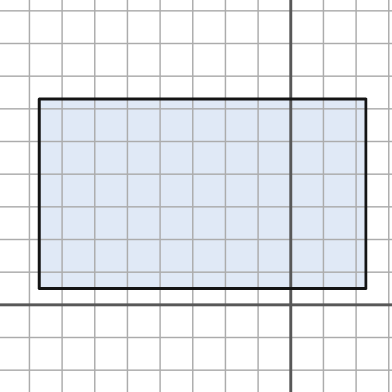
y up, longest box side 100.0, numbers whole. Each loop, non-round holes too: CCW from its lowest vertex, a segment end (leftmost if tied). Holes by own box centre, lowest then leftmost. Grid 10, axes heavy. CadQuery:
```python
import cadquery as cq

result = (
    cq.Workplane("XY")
    .moveTo(-77.0, 5.0)
    .lineTo(23.0, 5.0)
    .lineTo(23.0, 63.0)
    .lineTo(-77.0, 63.0)
    .close()
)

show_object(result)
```